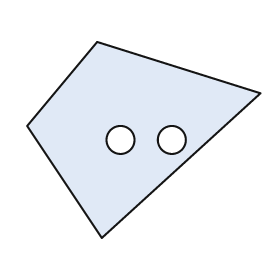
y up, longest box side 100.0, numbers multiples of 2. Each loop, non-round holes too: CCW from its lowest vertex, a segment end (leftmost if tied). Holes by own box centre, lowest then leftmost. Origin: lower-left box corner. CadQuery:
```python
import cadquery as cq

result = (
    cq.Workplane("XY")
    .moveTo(32.0, 0.0)
    .lineTo(100.0, 62.0)
    .lineTo(30.0, 84.0)
    .lineTo(0.0, 48.0)
    .close()
    .moveTo(40.0, 42.0)
    .circle(6.0)
    .moveTo(62.0, 42.0)
    .circle(6.0)
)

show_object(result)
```